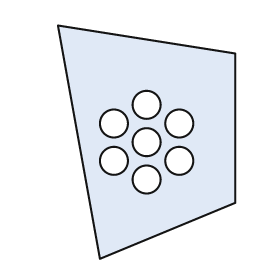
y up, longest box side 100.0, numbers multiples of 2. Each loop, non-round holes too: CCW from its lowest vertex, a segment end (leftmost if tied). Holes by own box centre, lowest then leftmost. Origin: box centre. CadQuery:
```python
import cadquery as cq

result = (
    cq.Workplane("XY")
    .moveTo(-20.0, -50.0)
    .lineTo(38.0, -26.0)
    .lineTo(38.0, 38.0)
    .lineTo(-38.0, 50.0)
    .close()
    .moveTo(0.0, -16.0)
    .circle(6.0)
    .moveTo(-14.0, -8.0)
    .circle(6.0)
    .moveTo(14.0, -8.0)
    .circle(6.0)
    .moveTo(0.0, 0.0)
    .circle(6.0)
    .moveTo(-14.0, 8.0)
    .circle(6.0)
    .moveTo(14.0, 8.0)
    .circle(6.0)
    .moveTo(0.0, 16.0)
    .circle(6.0)
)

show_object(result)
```